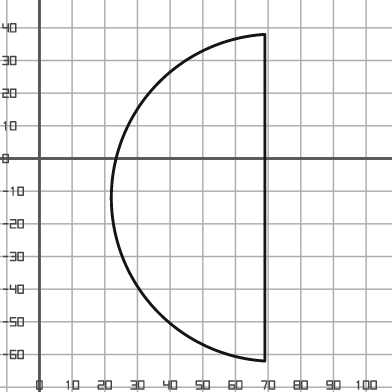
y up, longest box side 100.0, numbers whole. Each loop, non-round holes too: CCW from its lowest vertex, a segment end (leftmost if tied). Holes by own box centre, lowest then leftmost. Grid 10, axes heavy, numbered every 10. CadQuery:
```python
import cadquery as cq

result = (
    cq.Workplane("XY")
    .moveTo(69.0, -62.0)
    .lineTo(69.0, 38.0)
    .threePointArc((22.0, -12.0), (69.0, -62.0))
    .close()
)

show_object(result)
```